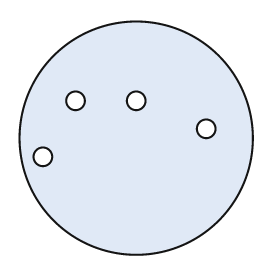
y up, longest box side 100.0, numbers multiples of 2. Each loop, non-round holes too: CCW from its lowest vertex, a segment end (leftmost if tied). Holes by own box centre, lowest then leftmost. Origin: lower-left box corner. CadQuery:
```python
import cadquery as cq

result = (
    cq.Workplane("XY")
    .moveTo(50.0, 50.0)
    .circle(50.0)
    .moveTo(10.0, 42.0)
    .circle(4.0)
    .moveTo(80.0, 54.0)
    .circle(4.0)
    .moveTo(24.0, 66.0)
    .circle(4.0)
    .moveTo(50.0, 66.0)
    .circle(4.0)
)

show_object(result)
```